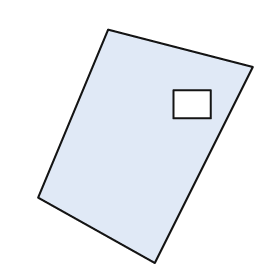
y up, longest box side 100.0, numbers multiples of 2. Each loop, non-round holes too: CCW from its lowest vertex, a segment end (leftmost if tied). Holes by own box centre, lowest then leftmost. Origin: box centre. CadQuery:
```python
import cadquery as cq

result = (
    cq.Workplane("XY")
    .moveTo(4.0, -50.0)
    .lineTo(46.0, 34.0)
    .lineTo(-16.0, 50.0)
    .lineTo(-46.0, -22.0)
    .close()
    .moveTo(12.0, 12.0)
    .lineTo(28.0, 12.0)
    .lineTo(28.0, 24.0)
    .lineTo(12.0, 24.0)
    .close()
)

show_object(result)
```